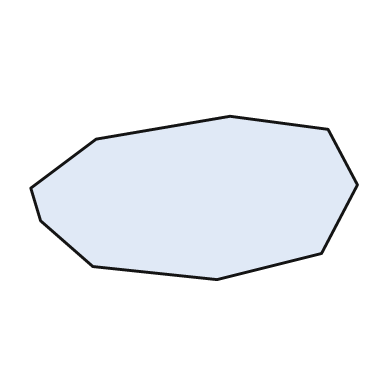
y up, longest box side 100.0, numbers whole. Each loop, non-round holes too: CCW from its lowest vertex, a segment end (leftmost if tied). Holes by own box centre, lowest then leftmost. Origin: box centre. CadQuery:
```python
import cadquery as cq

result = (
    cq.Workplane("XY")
    .moveTo(7.0, -25.0)
    .lineTo(39.0, -17.0)
    .lineTo(50.0, 4.0)
    .lineTo(41.0, 21.0)
    .lineTo(11.0, 25.0)
    .lineTo(-30.0, 18.0)
    .lineTo(-50.0, 3.0)
    .lineTo(-47.0, -7.0)
    .lineTo(-31.0, -21.0)
    .close()
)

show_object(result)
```